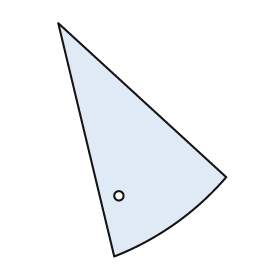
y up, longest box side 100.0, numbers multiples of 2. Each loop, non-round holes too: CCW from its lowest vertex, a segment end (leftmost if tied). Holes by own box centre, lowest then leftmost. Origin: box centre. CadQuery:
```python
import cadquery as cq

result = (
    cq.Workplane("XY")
    .moveTo(-12.0, -50.0)
    .threePointArc((14.0, -36.0), (36.0, -16.0))
    .lineTo(-36.0, 50.0)
    .close()
    .moveTo(-10.0, -24.0)
    .circle(2.0)
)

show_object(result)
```